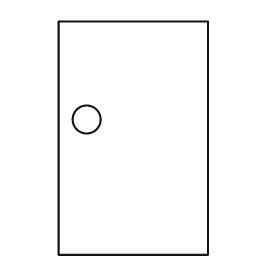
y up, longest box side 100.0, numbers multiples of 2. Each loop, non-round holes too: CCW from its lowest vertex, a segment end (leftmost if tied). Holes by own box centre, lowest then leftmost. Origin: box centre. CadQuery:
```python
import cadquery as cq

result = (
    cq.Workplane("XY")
    .moveTo(-32.0, -50.0)
    .lineTo(32.0, -50.0)
    .lineTo(32.0, 50.0)
    .lineTo(-32.0, 50.0)
    .close()
    .moveTo(-20.0, 8.0)
    .circle(6.0)
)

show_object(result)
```